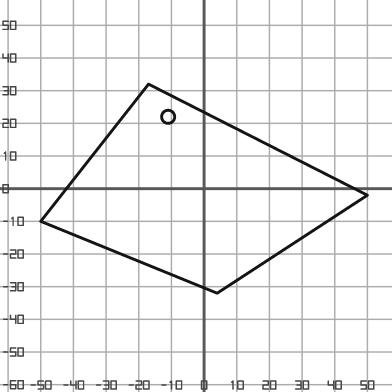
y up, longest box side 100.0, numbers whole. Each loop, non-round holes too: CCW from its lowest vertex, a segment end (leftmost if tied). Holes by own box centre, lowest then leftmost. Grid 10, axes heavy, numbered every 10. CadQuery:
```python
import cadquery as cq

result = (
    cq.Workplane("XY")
    .moveTo(4.0, -32.0)
    .lineTo(50.0, -2.0)
    .lineTo(-17.0, 32.0)
    .lineTo(-50.0, -10.0)
    .close()
    .moveTo(-11.0, 22.0)
    .circle(2.0)
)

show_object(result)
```